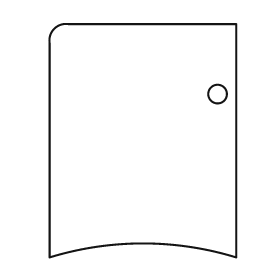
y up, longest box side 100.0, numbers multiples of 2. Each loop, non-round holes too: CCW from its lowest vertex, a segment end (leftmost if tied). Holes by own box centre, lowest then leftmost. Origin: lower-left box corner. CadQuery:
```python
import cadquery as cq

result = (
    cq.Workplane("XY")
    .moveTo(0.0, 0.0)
    .threePointArc((40.0, 6.0), (80.0, 0.0))
    .lineTo(80.0, 100.0)
    .lineTo(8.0, 100.0)
    .threePointArc((2.0, 98.0), (0.0, 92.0))
    .close()
    .moveTo(72.0, 70.0)
    .circle(4.0)
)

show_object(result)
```